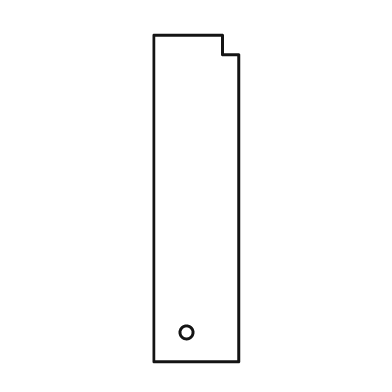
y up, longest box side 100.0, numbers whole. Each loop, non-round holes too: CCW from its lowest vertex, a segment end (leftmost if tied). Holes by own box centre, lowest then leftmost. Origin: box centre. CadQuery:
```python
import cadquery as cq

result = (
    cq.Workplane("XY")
    .moveTo(-13.0, -50.0)
    .lineTo(13.0, -50.0)
    .lineTo(13.0, 44.0)
    .lineTo(8.0, 44.0)
    .lineTo(8.0, 50.0)
    .lineTo(-13.0, 50.0)
    .close()
    .moveTo(-3.0, -41.0)
    .circle(2.0)
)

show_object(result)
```